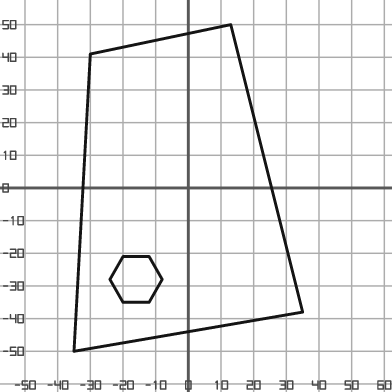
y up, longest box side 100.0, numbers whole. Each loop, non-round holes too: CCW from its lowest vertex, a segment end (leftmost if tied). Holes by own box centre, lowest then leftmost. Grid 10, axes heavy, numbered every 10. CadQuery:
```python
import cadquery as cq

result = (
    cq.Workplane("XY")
    .moveTo(-35.0, -50.0)
    .lineTo(35.0, -38.0)
    .lineTo(13.0, 50.0)
    .lineTo(-30.0, 41.0)
    .close()
    .moveTo(-20.0, -35.0)
    .lineTo(-12.0, -35.0)
    .lineTo(-8.0, -28.0)
    .lineTo(-12.0, -21.0)
    .lineTo(-20.0, -21.0)
    .lineTo(-24.0, -28.0)
    .close()
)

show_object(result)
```